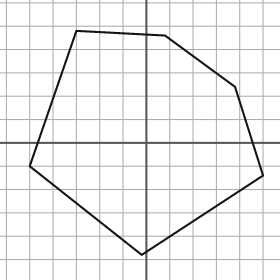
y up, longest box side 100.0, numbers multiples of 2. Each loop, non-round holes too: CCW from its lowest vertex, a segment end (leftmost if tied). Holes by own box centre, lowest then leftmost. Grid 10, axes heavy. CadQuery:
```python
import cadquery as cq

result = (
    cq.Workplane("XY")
    .moveTo(-2.0, -48.0)
    .lineTo(50.0, -14.0)
    .lineTo(38.0, 24.0)
    .lineTo(8.0, 46.0)
    .lineTo(-30.0, 48.0)
    .lineTo(-50.0, -10.0)
    .close()
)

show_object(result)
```